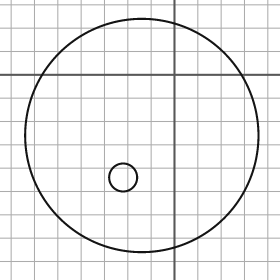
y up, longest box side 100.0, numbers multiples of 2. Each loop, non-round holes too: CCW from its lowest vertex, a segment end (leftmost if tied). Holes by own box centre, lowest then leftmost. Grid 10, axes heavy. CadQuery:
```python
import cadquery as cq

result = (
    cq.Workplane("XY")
    .moveTo(-14.0, -26.0)
    .circle(50.0)
    .moveTo(-22.0, -44.0)
    .circle(6.0)
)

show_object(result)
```